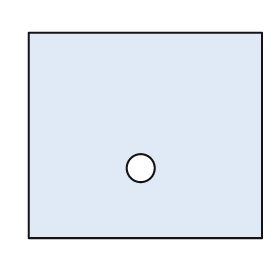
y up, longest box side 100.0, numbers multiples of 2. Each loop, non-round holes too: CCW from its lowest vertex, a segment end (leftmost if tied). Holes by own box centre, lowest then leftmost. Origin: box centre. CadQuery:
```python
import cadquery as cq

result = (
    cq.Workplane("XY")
    .moveTo(-50.0, -44.0)
    .lineTo(50.0, -44.0)
    .lineTo(50.0, 44.0)
    .lineTo(-50.0, 44.0)
    .close()
    .moveTo(-2.0, -14.0)
    .circle(6.0)
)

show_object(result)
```